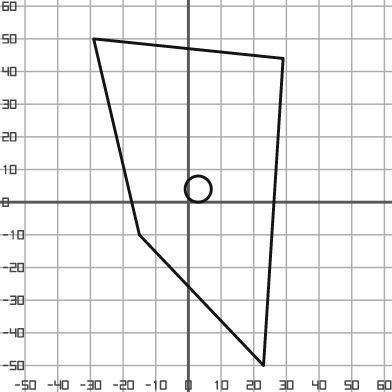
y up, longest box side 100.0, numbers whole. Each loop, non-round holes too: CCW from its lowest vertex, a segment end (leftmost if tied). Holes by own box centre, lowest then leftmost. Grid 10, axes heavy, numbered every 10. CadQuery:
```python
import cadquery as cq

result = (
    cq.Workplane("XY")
    .moveTo(23.0, -50.0)
    .lineTo(29.0, 44.0)
    .lineTo(-29.0, 50.0)
    .lineTo(-15.0, -10.0)
    .close()
    .moveTo(3.0, 4.0)
    .circle(4.0)
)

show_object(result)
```